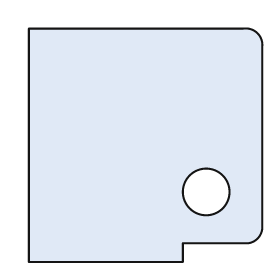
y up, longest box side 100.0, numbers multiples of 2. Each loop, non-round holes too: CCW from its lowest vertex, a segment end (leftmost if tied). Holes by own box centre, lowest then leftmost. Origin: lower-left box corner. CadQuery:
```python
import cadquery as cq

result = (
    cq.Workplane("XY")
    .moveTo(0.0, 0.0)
    .lineTo(66.0, 0.0)
    .lineTo(66.0, 8.0)
    .lineTo(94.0, 8.0)
    .threePointArc((98.0, 10.0), (100.0, 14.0))
    .lineTo(100.0, 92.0)
    .threePointArc((98.0, 98.0), (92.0, 100.0))
    .lineTo(0.0, 100.0)
    .close()
    .moveTo(76.0, 30.0)
    .circle(10.0)
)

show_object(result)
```